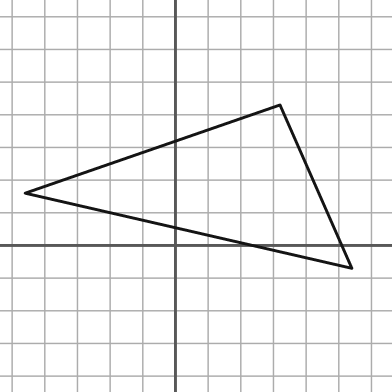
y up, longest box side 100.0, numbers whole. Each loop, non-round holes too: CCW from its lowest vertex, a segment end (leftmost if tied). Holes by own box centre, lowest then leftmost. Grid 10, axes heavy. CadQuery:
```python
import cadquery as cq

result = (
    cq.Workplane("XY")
    .moveTo(54.0, -7.0)
    .lineTo(32.0, 43.0)
    .lineTo(-46.0, 16.0)
    .close()
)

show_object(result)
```